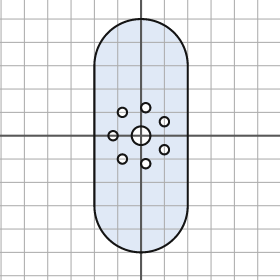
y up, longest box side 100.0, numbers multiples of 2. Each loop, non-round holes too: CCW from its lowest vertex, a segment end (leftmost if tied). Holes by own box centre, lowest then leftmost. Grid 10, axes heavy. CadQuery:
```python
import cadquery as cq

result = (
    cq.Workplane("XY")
    .moveTo(-20.0, -30.0)
    .threePointArc((0.0, -50.0), (20.0, -30.0))
    .lineTo(20.0, 30.0)
    .threePointArc((0.0, 50.0), (-20.0, 30.0))
    .close()
    .moveTo(2.0, -12.0)
    .circle(2.0)
    .moveTo(-8.0, -10.0)
    .circle(2.0)
    .moveTo(10.0, -6.0)
    .circle(2.0)
    .moveTo(-12.0, 0.0)
    .circle(2.0)
    .moveTo(0.0, 0.0)
    .circle(4.0)
    .moveTo(10.0, 6.0)
    .circle(2.0)
    .moveTo(-8.0, 10.0)
    .circle(2.0)
    .moveTo(2.0, 12.0)
    .circle(2.0)
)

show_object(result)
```